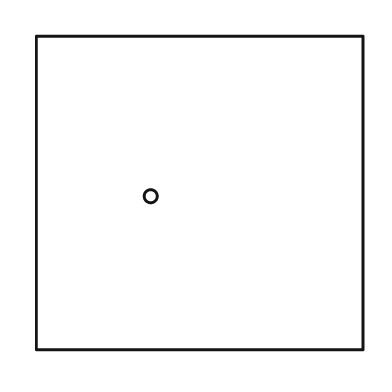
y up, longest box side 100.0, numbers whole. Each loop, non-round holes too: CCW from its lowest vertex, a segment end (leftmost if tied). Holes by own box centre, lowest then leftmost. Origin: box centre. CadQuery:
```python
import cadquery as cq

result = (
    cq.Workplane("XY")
    .moveTo(-50.0, -48.0)
    .lineTo(50.0, -48.0)
    .lineTo(50.0, 48.0)
    .lineTo(-50.0, 48.0)
    .close()
    .moveTo(-15.0, -1.0)
    .circle(2.0)
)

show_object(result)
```